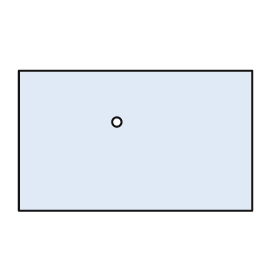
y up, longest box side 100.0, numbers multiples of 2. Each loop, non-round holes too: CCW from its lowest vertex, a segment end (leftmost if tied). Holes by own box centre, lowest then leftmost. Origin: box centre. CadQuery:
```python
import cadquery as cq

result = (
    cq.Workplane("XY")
    .moveTo(-50.0, -30.0)
    .lineTo(50.0, -30.0)
    .lineTo(50.0, 30.0)
    .lineTo(-50.0, 30.0)
    .close()
    .moveTo(-8.0, 8.0)
    .circle(2.0)
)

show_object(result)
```